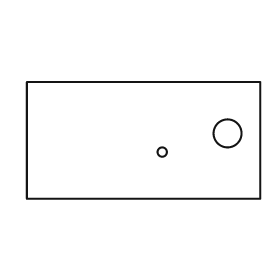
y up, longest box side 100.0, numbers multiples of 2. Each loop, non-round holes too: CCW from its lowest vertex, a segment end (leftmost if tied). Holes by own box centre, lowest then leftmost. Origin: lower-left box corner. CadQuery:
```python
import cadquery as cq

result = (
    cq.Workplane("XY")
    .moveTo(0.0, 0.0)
    .lineTo(100.0, 0.0)
    .lineTo(100.0, 50.0)
    .lineTo(0.0, 50.0)
    .close()
    .moveTo(58.0, 20.0)
    .circle(2.0)
    .moveTo(86.0, 28.0)
    .circle(6.0)
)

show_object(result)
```